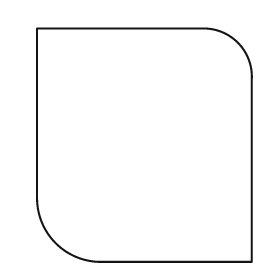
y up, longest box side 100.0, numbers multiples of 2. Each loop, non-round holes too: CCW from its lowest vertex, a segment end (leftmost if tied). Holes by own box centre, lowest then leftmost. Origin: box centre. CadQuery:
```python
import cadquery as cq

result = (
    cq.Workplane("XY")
    .moveTo(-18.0, -50.0)
    .lineTo(46.0, -50.0)
    .lineTo(46.0, 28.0)
    .threePointArc((40.0, 44.0), (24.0, 50.0))
    .lineTo(-46.0, 50.0)
    .lineTo(-46.0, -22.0)
    .threePointArc((-38.0, -42.0), (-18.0, -50.0))
    .close()
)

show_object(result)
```